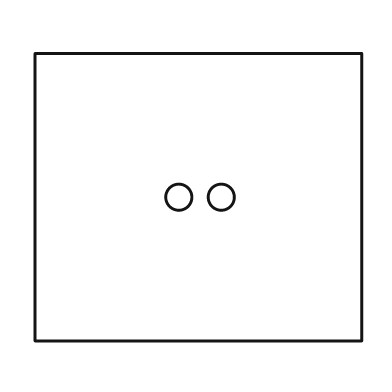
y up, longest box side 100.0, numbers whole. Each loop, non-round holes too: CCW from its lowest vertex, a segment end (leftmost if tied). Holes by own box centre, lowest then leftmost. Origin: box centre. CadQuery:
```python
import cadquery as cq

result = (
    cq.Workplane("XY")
    .moveTo(-50.0, -44.0)
    .lineTo(50.0, -44.0)
    .lineTo(50.0, 44.0)
    .lineTo(-50.0, 44.0)
    .close()
    .moveTo(-6.0, 0.0)
    .circle(4.0)
    .moveTo(7.0, 0.0)
    .circle(4.0)
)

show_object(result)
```